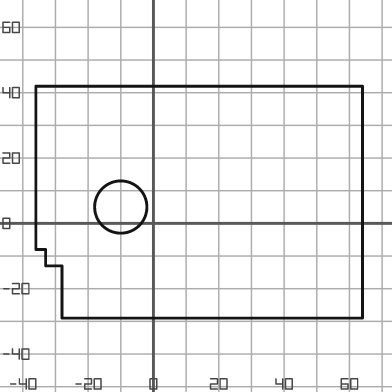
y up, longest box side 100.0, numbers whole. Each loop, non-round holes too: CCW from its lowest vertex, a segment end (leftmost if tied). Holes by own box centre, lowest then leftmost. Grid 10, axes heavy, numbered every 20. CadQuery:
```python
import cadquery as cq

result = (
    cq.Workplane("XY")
    .moveTo(-28.0, -29.0)
    .lineTo(64.0, -29.0)
    .lineTo(64.0, 42.0)
    .lineTo(-36.0, 42.0)
    .lineTo(-36.0, -8.0)
    .lineTo(-33.0, -8.0)
    .lineTo(-33.0, -13.0)
    .lineTo(-28.0, -13.0)
    .close()
    .moveTo(-10.0, 5.0)
    .circle(8.0)
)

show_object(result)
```